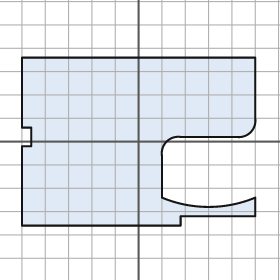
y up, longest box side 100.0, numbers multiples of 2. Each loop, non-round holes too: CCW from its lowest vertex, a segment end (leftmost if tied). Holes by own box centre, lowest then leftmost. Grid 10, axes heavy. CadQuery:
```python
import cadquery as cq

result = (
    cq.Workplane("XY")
    .moveTo(-50.0, -36.0)
    .lineTo(18.0, -36.0)
    .lineTo(18.0, -32.0)
    .lineTo(50.0, -32.0)
    .lineTo(50.0, -24.0)
    .threePointArc((30.0, -28.0), (10.0, -24.0))
    .lineTo(10.0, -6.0)
    .threePointArc((12.0, 0.0), (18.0, 2.0))
    .lineTo(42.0, 2.0)
    .threePointArc((48.0, 4.0), (50.0, 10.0))
    .lineTo(50.0, 36.0)
    .lineTo(-50.0, 36.0)
    .lineTo(-50.0, 6.0)
    .lineTo(-46.0, 6.0)
    .lineTo(-46.0, -2.0)
    .lineTo(-50.0, -2.0)
    .close()
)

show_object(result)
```